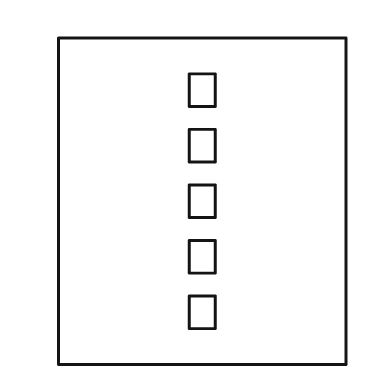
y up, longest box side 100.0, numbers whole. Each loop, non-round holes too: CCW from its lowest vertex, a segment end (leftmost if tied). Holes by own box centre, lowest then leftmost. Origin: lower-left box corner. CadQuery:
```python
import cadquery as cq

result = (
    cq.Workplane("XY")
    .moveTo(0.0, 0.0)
    .lineTo(88.0, 0.0)
    .lineTo(88.0, 100.0)
    .lineTo(0.0, 100.0)
    .close()
    .moveTo(40.0, 11.0)
    .lineTo(48.0, 11.0)
    .lineTo(48.0, 21.0)
    .lineTo(40.0, 21.0)
    .close()
    .moveTo(40.0, 28.0)
    .lineTo(48.0, 28.0)
    .lineTo(48.0, 38.0)
    .lineTo(40.0, 38.0)
    .close()
    .moveTo(40.0, 45.0)
    .lineTo(48.0, 45.0)
    .lineTo(48.0, 55.0)
    .lineTo(40.0, 55.0)
    .close()
    .moveTo(40.0, 62.0)
    .lineTo(48.0, 62.0)
    .lineTo(48.0, 72.0)
    .lineTo(40.0, 72.0)
    .close()
    .moveTo(40.0, 79.0)
    .lineTo(48.0, 79.0)
    .lineTo(48.0, 89.0)
    .lineTo(40.0, 89.0)
    .close()
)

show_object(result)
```